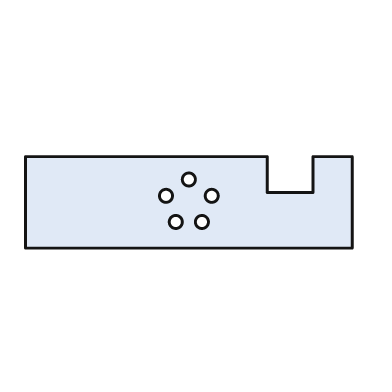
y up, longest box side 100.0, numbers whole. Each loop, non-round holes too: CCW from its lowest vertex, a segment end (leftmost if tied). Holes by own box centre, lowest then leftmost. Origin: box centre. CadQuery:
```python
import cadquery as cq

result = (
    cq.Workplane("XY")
    .moveTo(-50.0, -14.0)
    .lineTo(50.0, -14.0)
    .lineTo(50.0, 14.0)
    .lineTo(38.0, 14.0)
    .lineTo(38.0, 3.0)
    .lineTo(24.0, 3.0)
    .lineTo(24.0, 14.0)
    .lineTo(-50.0, 14.0)
    .close()
    .moveTo(-4.0, -6.0)
    .circle(2.0)
    .moveTo(4.0, -6.0)
    .circle(2.0)
    .moveTo(-7.0, 2.0)
    .circle(2.0)
    .moveTo(7.0, 2.0)
    .circle(2.0)
    .moveTo(0.0, 7.0)
    .circle(2.0)
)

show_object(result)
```